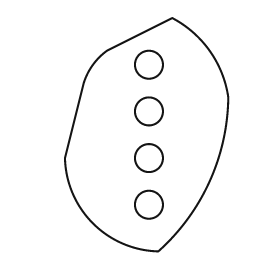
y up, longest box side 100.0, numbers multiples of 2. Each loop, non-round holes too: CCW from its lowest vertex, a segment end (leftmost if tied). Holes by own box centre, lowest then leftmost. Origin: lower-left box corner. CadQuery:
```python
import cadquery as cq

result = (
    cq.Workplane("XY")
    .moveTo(40.0, 0.0)
    .threePointArc((62.0, 30.0), (70.0, 66.0))
    .threePointArc((62.0, 86.0), (46.0, 100.0))
    .lineTo(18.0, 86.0)
    .threePointArc((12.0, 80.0), (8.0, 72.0))
    .lineTo(0.0, 40.0)
    .threePointArc((12.0, 12.0), (40.0, 0.0))
    .close()
    .moveTo(36.0, 20.0)
    .circle(6.0)
    .moveTo(36.0, 40.0)
    .circle(6.0)
    .moveTo(36.0, 60.0)
    .circle(6.0)
    .moveTo(36.0, 80.0)
    .circle(6.0)
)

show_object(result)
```